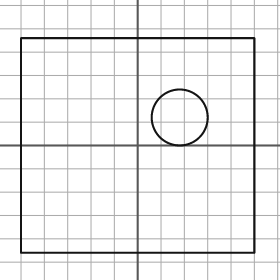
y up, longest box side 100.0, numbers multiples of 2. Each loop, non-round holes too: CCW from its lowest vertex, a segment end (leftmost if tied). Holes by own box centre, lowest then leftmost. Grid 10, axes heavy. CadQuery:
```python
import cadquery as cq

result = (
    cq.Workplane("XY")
    .moveTo(-50.0, -46.0)
    .lineTo(50.0, -46.0)
    .lineTo(50.0, 46.0)
    .lineTo(-50.0, 46.0)
    .close()
    .moveTo(18.0, 12.0)
    .circle(12.0)
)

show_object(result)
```